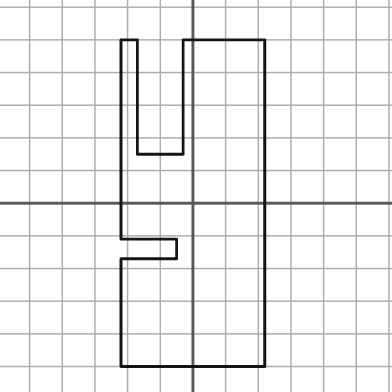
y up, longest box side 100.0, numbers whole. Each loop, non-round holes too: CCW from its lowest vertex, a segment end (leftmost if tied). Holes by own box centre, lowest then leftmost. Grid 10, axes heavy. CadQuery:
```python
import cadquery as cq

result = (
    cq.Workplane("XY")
    .moveTo(-22.0, -50.0)
    .lineTo(22.0, -50.0)
    .lineTo(22.0, 50.0)
    .lineTo(-3.0, 50.0)
    .lineTo(-3.0, 15.0)
    .lineTo(-17.0, 15.0)
    .lineTo(-17.0, 50.0)
    .lineTo(-22.0, 50.0)
    .lineTo(-22.0, -11.0)
    .lineTo(-5.0, -11.0)
    .lineTo(-5.0, -17.0)
    .lineTo(-22.0, -17.0)
    .close()
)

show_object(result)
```